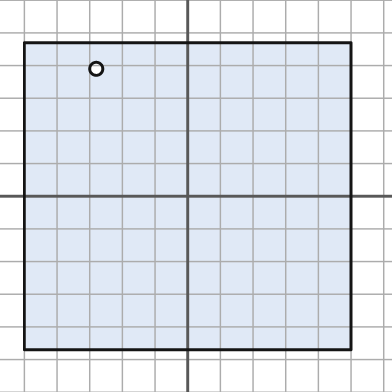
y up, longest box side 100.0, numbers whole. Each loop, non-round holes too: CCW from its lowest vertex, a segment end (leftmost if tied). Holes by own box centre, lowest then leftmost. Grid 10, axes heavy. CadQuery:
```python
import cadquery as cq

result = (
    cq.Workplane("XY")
    .moveTo(-50.0, -47.0)
    .lineTo(50.0, -47.0)
    .lineTo(50.0, 47.0)
    .lineTo(-50.0, 47.0)
    .close()
    .moveTo(-28.0, 39.0)
    .circle(2.0)
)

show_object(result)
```